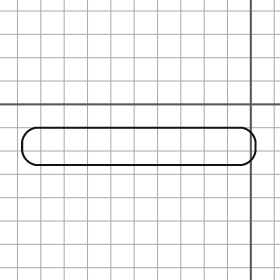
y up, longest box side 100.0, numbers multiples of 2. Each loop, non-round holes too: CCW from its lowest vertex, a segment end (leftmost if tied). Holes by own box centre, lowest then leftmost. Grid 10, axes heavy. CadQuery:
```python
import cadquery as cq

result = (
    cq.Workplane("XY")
    .moveTo(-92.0, -26.0)
    .lineTo(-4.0, -26.0)
    .threePointArc((0.0, -24.0), (2.0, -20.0))
    .lineTo(2.0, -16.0)
    .threePointArc((0.0, -12.0), (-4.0, -10.0))
    .lineTo(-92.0, -10.0)
    .threePointArc((-96.0, -12.0), (-98.0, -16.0))
    .lineTo(-98.0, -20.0)
    .threePointArc((-96.0, -24.0), (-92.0, -26.0))
    .close()
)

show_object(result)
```